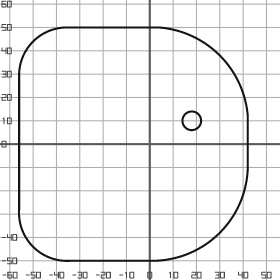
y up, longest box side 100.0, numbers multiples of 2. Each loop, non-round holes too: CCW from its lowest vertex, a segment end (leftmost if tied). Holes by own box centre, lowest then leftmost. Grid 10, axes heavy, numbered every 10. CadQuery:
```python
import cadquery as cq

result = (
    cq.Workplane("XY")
    .moveTo(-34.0, -50.0)
    .lineTo(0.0, -50.0)
    .threePointArc((30.0, -38.0), (42.0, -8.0))
    .lineTo(42.0, 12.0)
    .threePointArc((30.0, 38.0), (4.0, 50.0))
    .lineTo(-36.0, 50.0)
    .threePointArc((-50.0, 44.0), (-56.0, 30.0))
    .lineTo(-56.0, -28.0)
    .threePointArc((-50.0, -44.0), (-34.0, -50.0))
    .close()
    .moveTo(18.0, 10.0)
    .circle(4.0)
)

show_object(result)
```